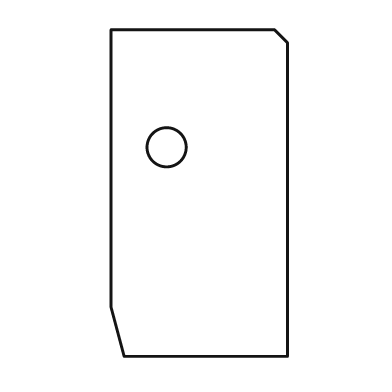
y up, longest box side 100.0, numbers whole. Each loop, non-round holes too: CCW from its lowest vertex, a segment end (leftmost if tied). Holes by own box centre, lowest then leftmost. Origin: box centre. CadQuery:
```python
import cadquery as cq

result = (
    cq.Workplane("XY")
    .moveTo(-23.0, -50.0)
    .lineTo(27.0, -50.0)
    .lineTo(27.0, 46.0)
    .lineTo(23.0, 50.0)
    .lineTo(-27.0, 50.0)
    .lineTo(-27.0, -35.0)
    .close()
    .moveTo(-10.0, 14.0)
    .circle(6.0)
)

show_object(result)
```